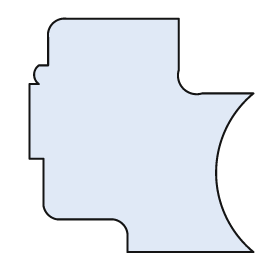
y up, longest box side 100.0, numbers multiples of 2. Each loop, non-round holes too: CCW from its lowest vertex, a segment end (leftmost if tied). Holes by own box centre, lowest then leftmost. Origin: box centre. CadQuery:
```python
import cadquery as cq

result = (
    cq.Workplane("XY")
    .moveTo(-6.0, -50.0)
    .lineTo(48.0, -50.0)
    .threePointArc((32.0, -16.0), (48.0, 18.0))
    .lineTo(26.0, 18.0)
    .threePointArc((18.0, 20.0), (16.0, 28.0))
    .lineTo(16.0, 50.0)
    .lineTo(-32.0, 50.0)
    .threePointArc((-38.0, 48.0), (-40.0, 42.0))
    .lineTo(-40.0, 30.0)
    .lineTo(-44.0, 30.0)
    .threePointArc((-46.0, 26.0), (-44.0, 22.0))
    .lineTo(-48.0, 22.0)
    .lineTo(-48.0, -10.0)
    .lineTo(-42.0, -10.0)
    .lineTo(-42.0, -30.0)
    .threePointArc((-40.0, -34.0), (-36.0, -36.0))
    .lineTo(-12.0, -36.0)
    .threePointArc((-8.0, -38.0), (-6.0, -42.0))
    .close()
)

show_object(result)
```